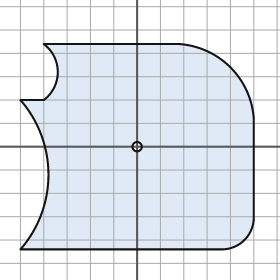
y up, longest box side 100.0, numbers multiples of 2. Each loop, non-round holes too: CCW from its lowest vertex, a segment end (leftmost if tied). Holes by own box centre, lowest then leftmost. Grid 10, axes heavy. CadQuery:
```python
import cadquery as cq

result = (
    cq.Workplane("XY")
    .moveTo(-50.0, -44.0)
    .lineTo(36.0, -44.0)
    .threePointArc((46.0, -40.0), (50.0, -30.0))
    .lineTo(50.0, 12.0)
    .threePointArc((40.0, 34.0), (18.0, 44.0))
    .lineTo(-40.0, 44.0)
    .threePointArc((-34.0, 32.0), (-40.0, 20.0))
    .lineTo(-50.0, 20.0)
    .threePointArc((-38.0, -12.0), (-50.0, -44.0))
    .close()
    .moveTo(0.0, 0.0)
    .circle(2.0)
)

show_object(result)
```